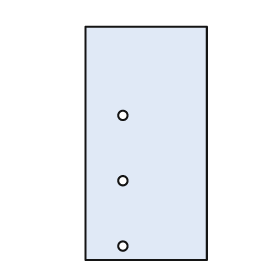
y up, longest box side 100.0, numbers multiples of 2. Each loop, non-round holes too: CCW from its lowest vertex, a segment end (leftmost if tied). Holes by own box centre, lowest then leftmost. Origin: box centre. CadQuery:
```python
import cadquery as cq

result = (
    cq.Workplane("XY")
    .moveTo(-26.0, -50.0)
    .lineTo(26.0, -50.0)
    .lineTo(26.0, 50.0)
    .lineTo(-26.0, 50.0)
    .close()
    .moveTo(-10.0, -44.0)
    .circle(2.0)
    .moveTo(-10.0, -16.0)
    .circle(2.0)
    .moveTo(-10.0, 12.0)
    .circle(2.0)
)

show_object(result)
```